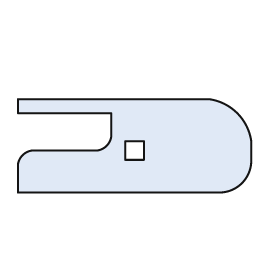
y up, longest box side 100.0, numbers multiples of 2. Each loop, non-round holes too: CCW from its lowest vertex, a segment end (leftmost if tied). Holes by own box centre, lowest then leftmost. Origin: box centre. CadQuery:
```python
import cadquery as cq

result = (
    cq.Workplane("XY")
    .moveTo(-50.0, -20.0)
    .lineTo(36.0, -20.0)
    .threePointArc((46.0, -16.0), (50.0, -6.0))
    .lineTo(50.0, 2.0)
    .threePointArc((44.0, 14.0), (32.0, 20.0))
    .lineTo(-50.0, 20.0)
    .lineTo(-50.0, 14.0)
    .lineTo(-10.0, 14.0)
    .lineTo(-10.0, 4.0)
    .threePointArc((-12.0, 0.0), (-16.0, -2.0))
    .lineTo(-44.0, -2.0)
    .threePointArc((-48.0, -4.0), (-50.0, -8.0))
    .close()
    .moveTo(-4.0, -6.0)
    .lineTo(4.0, -6.0)
    .lineTo(4.0, 2.0)
    .lineTo(-4.0, 2.0)
    .close()
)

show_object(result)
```